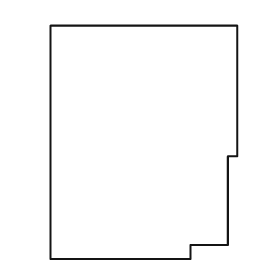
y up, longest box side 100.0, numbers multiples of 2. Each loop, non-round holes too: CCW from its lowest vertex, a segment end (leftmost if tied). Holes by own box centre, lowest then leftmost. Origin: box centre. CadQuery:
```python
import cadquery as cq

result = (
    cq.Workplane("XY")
    .moveTo(-40.0, -50.0)
    .lineTo(20.0, -50.0)
    .lineTo(20.0, -44.0)
    .lineTo(36.0, -44.0)
    .lineTo(36.0, -6.0)
    .lineTo(40.0, -6.0)
    .lineTo(40.0, 50.0)
    .lineTo(-40.0, 50.0)
    .close()
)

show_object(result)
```